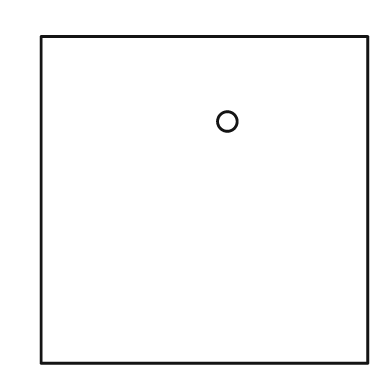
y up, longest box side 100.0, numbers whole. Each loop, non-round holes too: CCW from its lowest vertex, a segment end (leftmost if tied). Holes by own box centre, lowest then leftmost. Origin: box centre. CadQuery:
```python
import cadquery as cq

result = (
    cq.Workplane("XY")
    .moveTo(-50.0, -50.0)
    .lineTo(50.0, -50.0)
    .lineTo(50.0, 50.0)
    .lineTo(-50.0, 50.0)
    .close()
    .moveTo(7.0, 24.0)
    .circle(3.0)
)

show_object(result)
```